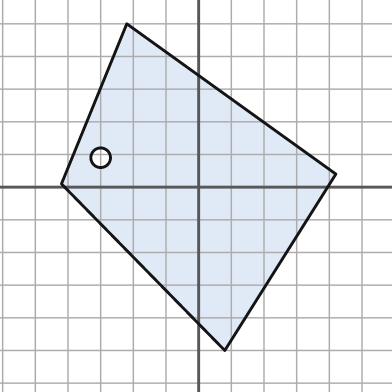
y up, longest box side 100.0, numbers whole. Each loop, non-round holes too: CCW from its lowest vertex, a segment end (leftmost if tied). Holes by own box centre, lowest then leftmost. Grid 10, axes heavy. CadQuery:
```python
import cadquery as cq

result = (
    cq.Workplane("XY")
    .moveTo(8.0, -50.0)
    .lineTo(42.0, 4.0)
    .lineTo(-22.0, 50.0)
    .lineTo(-42.0, 1.0)
    .close()
    .moveTo(-30.0, 9.0)
    .circle(3.0)
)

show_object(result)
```